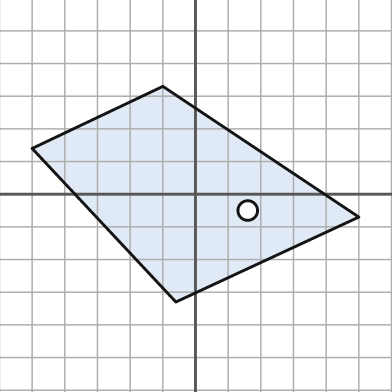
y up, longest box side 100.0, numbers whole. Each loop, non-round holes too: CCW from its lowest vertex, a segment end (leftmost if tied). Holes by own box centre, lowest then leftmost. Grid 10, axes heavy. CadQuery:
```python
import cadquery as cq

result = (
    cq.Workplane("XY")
    .moveTo(-6.0, -33.0)
    .lineTo(50.0, -7.0)
    .lineTo(-10.0, 33.0)
    .lineTo(-50.0, 14.0)
    .close()
    .moveTo(16.0, -5.0)
    .circle(3.0)
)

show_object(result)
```